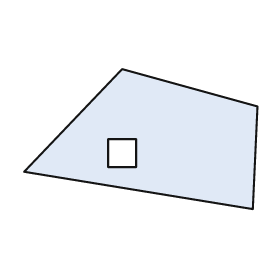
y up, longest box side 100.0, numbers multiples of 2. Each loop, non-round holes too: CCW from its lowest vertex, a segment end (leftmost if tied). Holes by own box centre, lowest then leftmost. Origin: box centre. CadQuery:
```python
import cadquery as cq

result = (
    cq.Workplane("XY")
    .moveTo(48.0, -30.0)
    .lineTo(50.0, 14.0)
    .lineTo(-8.0, 30.0)
    .lineTo(-50.0, -14.0)
    .close()
    .moveTo(-14.0, -12.0)
    .lineTo(-2.0, -12.0)
    .lineTo(-2.0, 0.0)
    .lineTo(-14.0, 0.0)
    .close()
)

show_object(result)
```